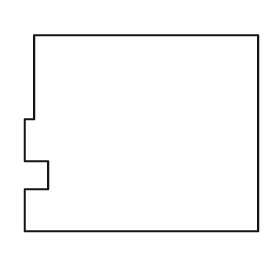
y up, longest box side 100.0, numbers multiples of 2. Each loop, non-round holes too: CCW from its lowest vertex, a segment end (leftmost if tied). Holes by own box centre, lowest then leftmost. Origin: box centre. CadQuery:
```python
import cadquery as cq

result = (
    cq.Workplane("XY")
    .moveTo(-50.0, -42.0)
    .lineTo(50.0, -42.0)
    .lineTo(50.0, 42.0)
    .lineTo(-46.0, 42.0)
    .lineTo(-46.0, 6.0)
    .lineTo(-50.0, 6.0)
    .lineTo(-50.0, -12.0)
    .lineTo(-40.0, -12.0)
    .lineTo(-40.0, -24.0)
    .lineTo(-50.0, -24.0)
    .close()
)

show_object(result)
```